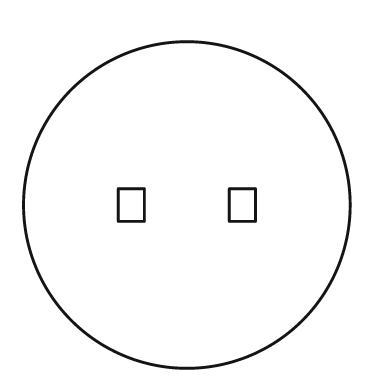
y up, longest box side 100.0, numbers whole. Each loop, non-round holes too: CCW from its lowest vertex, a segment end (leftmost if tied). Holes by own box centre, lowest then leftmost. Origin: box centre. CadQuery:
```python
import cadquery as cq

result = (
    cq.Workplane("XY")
    .moveTo(0.0, 0.0)
    .circle(50.0)
    .moveTo(-21.0, -5.0)
    .lineTo(-13.0, -5.0)
    .lineTo(-13.0, 5.0)
    .lineTo(-21.0, 5.0)
    .close()
    .moveTo(13.0, -5.0)
    .lineTo(21.0, -5.0)
    .lineTo(21.0, 5.0)
    .lineTo(13.0, 5.0)
    .close()
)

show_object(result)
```